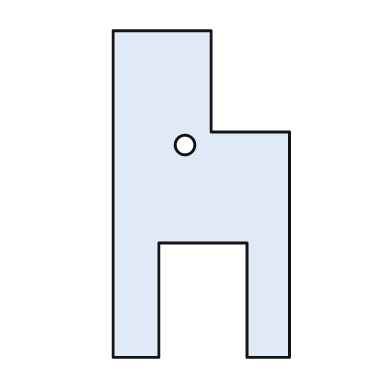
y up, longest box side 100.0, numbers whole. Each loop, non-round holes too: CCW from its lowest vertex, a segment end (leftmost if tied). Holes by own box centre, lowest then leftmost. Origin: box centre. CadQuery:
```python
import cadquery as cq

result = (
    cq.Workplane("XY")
    .moveTo(-27.0, -50.0)
    .lineTo(-13.0, -50.0)
    .lineTo(-13.0, -15.0)
    .lineTo(14.0, -15.0)
    .lineTo(14.0, -50.0)
    .lineTo(27.0, -50.0)
    .lineTo(27.0, 19.0)
    .lineTo(3.0, 19.0)
    .lineTo(3.0, 50.0)
    .lineTo(-27.0, 50.0)
    .close()
    .moveTo(-5.0, 15.0)
    .circle(3.0)
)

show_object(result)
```